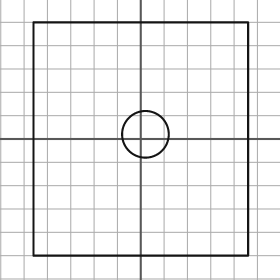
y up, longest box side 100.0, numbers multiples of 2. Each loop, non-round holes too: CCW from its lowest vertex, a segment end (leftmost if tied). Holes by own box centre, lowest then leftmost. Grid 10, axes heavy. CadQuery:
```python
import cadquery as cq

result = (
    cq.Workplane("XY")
    .moveTo(-46.0, -50.0)
    .lineTo(46.0, -50.0)
    .lineTo(46.0, 50.0)
    .lineTo(-46.0, 50.0)
    .close()
    .moveTo(2.0, 2.0)
    .circle(10.0)
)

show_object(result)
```